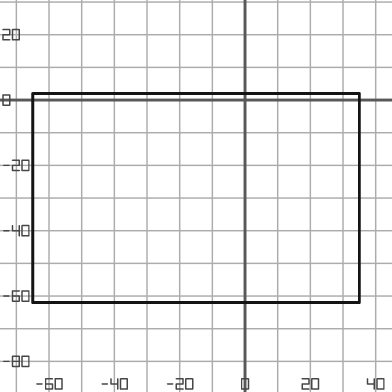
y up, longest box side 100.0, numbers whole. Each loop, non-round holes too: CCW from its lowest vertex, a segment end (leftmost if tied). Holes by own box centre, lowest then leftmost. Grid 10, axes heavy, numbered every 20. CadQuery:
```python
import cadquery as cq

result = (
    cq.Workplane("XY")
    .moveTo(-65.0, -62.0)
    .lineTo(35.0, -62.0)
    .lineTo(35.0, 2.0)
    .lineTo(-65.0, 2.0)
    .close()
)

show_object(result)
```